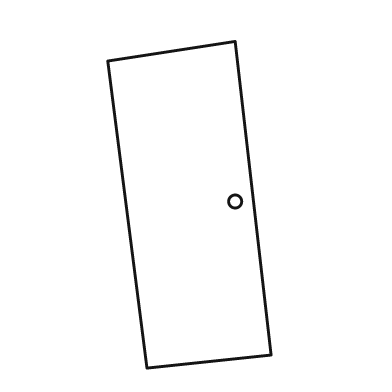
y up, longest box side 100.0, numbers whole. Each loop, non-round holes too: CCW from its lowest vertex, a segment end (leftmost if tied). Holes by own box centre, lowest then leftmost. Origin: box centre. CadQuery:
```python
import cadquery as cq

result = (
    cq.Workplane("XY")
    .moveTo(-13.0, -50.0)
    .lineTo(25.0, -46.0)
    .lineTo(14.0, 50.0)
    .lineTo(-25.0, 44.0)
    .close()
    .moveTo(14.0, 1.0)
    .circle(2.0)
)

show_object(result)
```